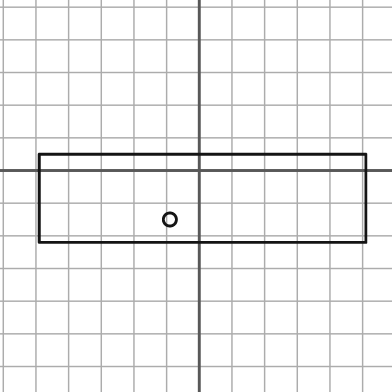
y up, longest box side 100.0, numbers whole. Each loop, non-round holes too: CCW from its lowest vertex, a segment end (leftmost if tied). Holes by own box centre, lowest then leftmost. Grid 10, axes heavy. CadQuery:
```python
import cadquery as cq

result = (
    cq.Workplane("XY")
    .moveTo(-49.0, -22.0)
    .lineTo(51.0, -22.0)
    .lineTo(51.0, 5.0)
    .lineTo(-49.0, 5.0)
    .close()
    .moveTo(-9.0, -15.0)
    .circle(2.0)
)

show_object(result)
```